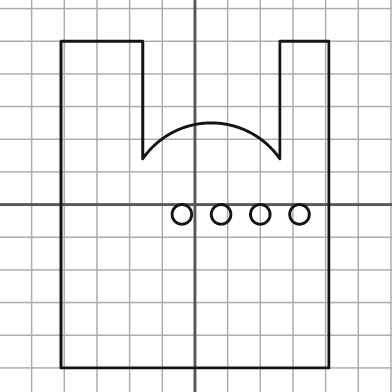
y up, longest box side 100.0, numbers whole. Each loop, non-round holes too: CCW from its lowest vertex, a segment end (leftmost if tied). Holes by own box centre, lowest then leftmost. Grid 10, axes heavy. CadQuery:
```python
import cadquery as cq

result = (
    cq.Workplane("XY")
    .moveTo(-41.0, -50.0)
    .lineTo(41.0, -50.0)
    .lineTo(41.0, 50.0)
    .lineTo(26.0, 50.0)
    .lineTo(26.0, 14.0)
    .threePointArc((5.0, 25.0), (-16.0, 14.0))
    .lineTo(-16.0, 50.0)
    .lineTo(-41.0, 50.0)
    .close()
    .moveTo(-4.0, -3.0)
    .circle(3.0)
    .moveTo(8.0, -3.0)
    .circle(3.0)
    .moveTo(20.0, -3.0)
    .circle(3.0)
    .moveTo(32.0, -3.0)
    .circle(3.0)
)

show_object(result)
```